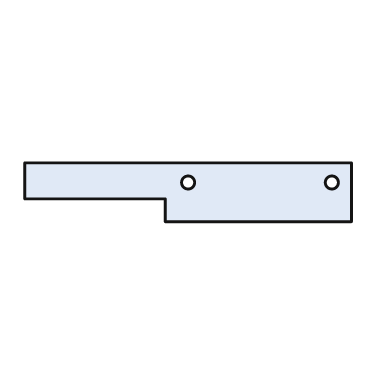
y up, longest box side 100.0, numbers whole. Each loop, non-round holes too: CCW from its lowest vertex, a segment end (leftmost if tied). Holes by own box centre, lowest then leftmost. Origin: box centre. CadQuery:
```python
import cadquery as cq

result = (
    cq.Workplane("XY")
    .moveTo(-7.0, -9.0)
    .lineTo(50.0, -9.0)
    .lineTo(50.0, 9.0)
    .lineTo(-50.0, 9.0)
    .lineTo(-50.0, -2.0)
    .lineTo(-7.0, -2.0)
    .close()
    .moveTo(0.0, 3.0)
    .circle(2.0)
    .moveTo(44.0, 3.0)
    .circle(2.0)
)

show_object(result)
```